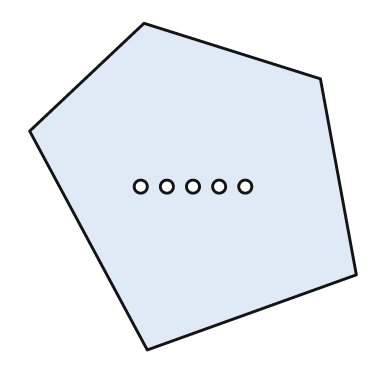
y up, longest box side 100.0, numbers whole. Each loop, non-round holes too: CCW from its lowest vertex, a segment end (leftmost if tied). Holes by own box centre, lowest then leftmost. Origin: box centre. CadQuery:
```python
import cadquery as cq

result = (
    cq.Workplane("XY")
    .moveTo(-14.0, -50.0)
    .lineTo(50.0, -27.0)
    .lineTo(39.0, 33.0)
    .lineTo(-15.0, 50.0)
    .lineTo(-50.0, 17.0)
    .close()
    .moveTo(-16.0, 0.0)
    .circle(2.0)
    .moveTo(-8.0, 0.0)
    .circle(2.0)
    .moveTo(0.0, 0.0)
    .circle(2.0)
    .moveTo(8.0, 0.0)
    .circle(2.0)
    .moveTo(16.0, 0.0)
    .circle(2.0)
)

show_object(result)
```